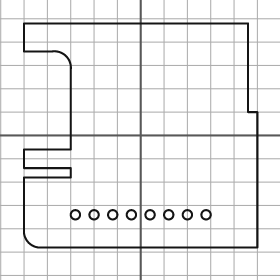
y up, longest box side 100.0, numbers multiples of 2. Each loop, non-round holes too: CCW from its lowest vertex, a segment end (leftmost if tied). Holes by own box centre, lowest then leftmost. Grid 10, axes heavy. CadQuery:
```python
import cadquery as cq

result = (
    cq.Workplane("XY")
    .moveTo(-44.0, -48.0)
    .lineTo(50.0, -48.0)
    .lineTo(50.0, 10.0)
    .lineTo(46.0, 10.0)
    .lineTo(46.0, 48.0)
    .lineTo(-50.0, 48.0)
    .lineTo(-50.0, 36.0)
    .lineTo(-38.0, 36.0)
    .threePointArc((-32.0, 34.0), (-30.0, 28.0))
    .lineTo(-30.0, -6.0)
    .lineTo(-50.0, -6.0)
    .lineTo(-50.0, -14.0)
    .lineTo(-30.0, -14.0)
    .lineTo(-30.0, -18.0)
    .lineTo(-50.0, -18.0)
    .lineTo(-50.0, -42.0)
    .threePointArc((-48.0, -46.0), (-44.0, -48.0))
    .close()
    .moveTo(-28.0, -34.0)
    .circle(2.0)
    .moveTo(-20.0, -34.0)
    .circle(2.0)
    .moveTo(-12.0, -34.0)
    .circle(2.0)
    .moveTo(-4.0, -34.0)
    .circle(2.0)
    .moveTo(4.0, -34.0)
    .circle(2.0)
    .moveTo(12.0, -34.0)
    .circle(2.0)
    .moveTo(20.0, -34.0)
    .circle(2.0)
    .moveTo(28.0, -34.0)
    .circle(2.0)
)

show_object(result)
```